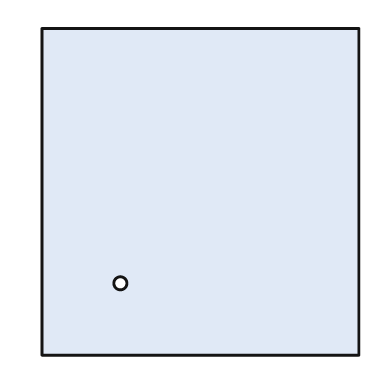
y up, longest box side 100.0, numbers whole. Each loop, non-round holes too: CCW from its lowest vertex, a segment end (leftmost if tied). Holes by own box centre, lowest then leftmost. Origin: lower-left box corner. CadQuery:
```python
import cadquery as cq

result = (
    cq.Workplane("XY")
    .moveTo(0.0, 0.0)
    .lineTo(97.0, 0.0)
    .lineTo(97.0, 100.0)
    .lineTo(0.0, 100.0)
    .close()
    .moveTo(24.0, 22.0)
    .circle(2.0)
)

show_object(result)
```